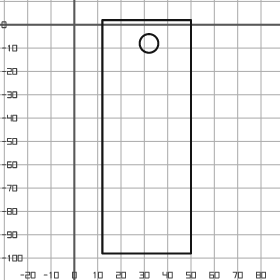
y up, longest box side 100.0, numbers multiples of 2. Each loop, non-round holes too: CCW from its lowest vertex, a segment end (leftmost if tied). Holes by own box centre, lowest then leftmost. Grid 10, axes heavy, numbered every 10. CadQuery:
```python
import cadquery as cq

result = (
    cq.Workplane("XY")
    .moveTo(12.0, -98.0)
    .lineTo(50.0, -98.0)
    .lineTo(50.0, 2.0)
    .lineTo(12.0, 2.0)
    .close()
    .moveTo(32.0, -8.0)
    .circle(4.0)
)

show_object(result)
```